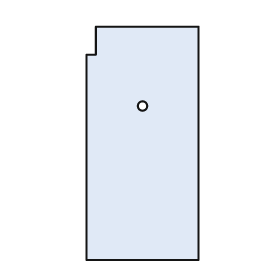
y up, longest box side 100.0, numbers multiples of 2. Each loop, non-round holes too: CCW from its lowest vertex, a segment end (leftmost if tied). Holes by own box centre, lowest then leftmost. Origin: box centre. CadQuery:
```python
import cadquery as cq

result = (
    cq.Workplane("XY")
    .moveTo(-24.0, -50.0)
    .lineTo(24.0, -50.0)
    .lineTo(24.0, 50.0)
    .lineTo(-20.0, 50.0)
    .lineTo(-20.0, 38.0)
    .lineTo(-24.0, 38.0)
    .close()
    .moveTo(0.0, 16.0)
    .circle(2.0)
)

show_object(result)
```